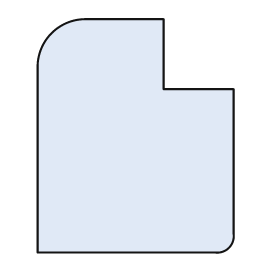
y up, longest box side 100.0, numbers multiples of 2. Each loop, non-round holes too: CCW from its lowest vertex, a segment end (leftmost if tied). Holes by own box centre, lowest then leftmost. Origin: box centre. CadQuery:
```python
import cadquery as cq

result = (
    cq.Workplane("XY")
    .moveTo(-42.0, -50.0)
    .lineTo(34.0, -50.0)
    .threePointArc((40.0, -48.0), (42.0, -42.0))
    .lineTo(42.0, 20.0)
    .lineTo(12.0, 20.0)
    .lineTo(12.0, 50.0)
    .lineTo(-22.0, 50.0)
    .threePointArc((-36.0, 44.0), (-42.0, 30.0))
    .close()
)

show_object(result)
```